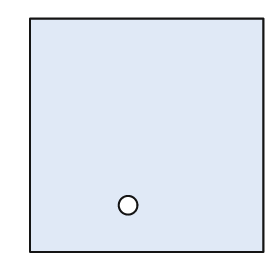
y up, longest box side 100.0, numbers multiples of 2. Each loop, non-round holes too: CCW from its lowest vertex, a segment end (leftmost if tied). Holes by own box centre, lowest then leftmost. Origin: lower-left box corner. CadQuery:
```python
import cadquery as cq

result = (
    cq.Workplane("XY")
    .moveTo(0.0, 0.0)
    .lineTo(100.0, 0.0)
    .lineTo(100.0, 100.0)
    .lineTo(0.0, 100.0)
    .close()
    .moveTo(42.0, 20.0)
    .circle(4.0)
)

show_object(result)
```